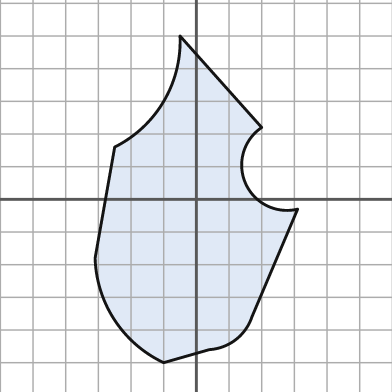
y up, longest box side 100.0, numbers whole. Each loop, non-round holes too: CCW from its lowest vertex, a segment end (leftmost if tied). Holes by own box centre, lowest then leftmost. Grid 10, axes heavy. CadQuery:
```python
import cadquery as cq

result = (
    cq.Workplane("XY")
    .moveTo(-10.0, -50.0)
    .lineTo(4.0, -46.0)
    .threePointArc((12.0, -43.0), (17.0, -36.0))
    .lineTo(31.0, -3.0)
    .threePointArc((15.0, 5.0), (20.0, 22.0))
    .lineTo(-5.0, 50.0)
    .threePointArc((-10.0, 30.0), (-25.0, 16.0))
    .lineTo(-31.0, -18.0)
    .threePointArc((-25.0, -37.0), (-10.0, -50.0))
    .close()
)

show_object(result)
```